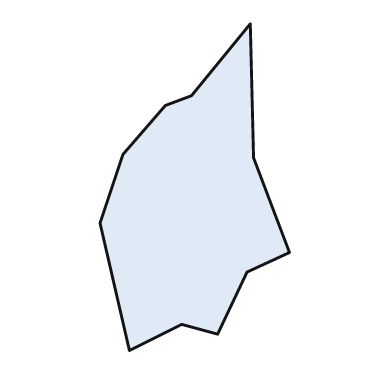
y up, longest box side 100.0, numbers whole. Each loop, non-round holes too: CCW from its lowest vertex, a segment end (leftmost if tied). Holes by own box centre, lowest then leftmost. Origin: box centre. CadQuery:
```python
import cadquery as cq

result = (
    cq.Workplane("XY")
    .moveTo(-20.0, -50.0)
    .lineTo(-4.0, -42.0)
    .lineTo(7.0, -45.0)
    .lineTo(16.0, -26.0)
    .lineTo(29.0, -20.0)
    .lineTo(18.0, 9.0)
    .lineTo(17.0, 50.0)
    .lineTo(-1.0, 28.0)
    .lineTo(-9.0, 25.0)
    .lineTo(-22.0, 10.0)
    .lineTo(-29.0, -11.0)
    .close()
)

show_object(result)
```